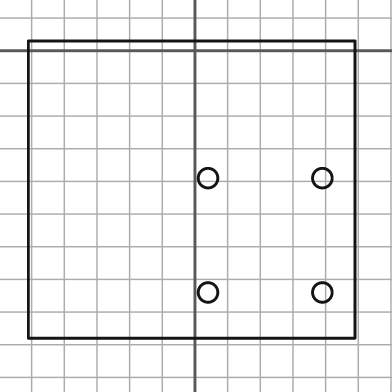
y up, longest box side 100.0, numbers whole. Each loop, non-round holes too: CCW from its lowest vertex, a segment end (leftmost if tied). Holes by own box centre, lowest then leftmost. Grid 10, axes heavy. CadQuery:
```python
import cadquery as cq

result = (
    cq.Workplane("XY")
    .moveTo(-51.0, -88.0)
    .lineTo(49.0, -88.0)
    .lineTo(49.0, 3.0)
    .lineTo(-51.0, 3.0)
    .close()
    .moveTo(4.0, -74.0)
    .circle(3.0)
    .moveTo(39.0, -74.0)
    .circle(3.0)
    .moveTo(4.0, -39.0)
    .circle(3.0)
    .moveTo(39.0, -39.0)
    .circle(3.0)
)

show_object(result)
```